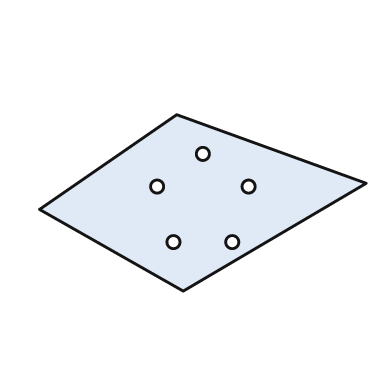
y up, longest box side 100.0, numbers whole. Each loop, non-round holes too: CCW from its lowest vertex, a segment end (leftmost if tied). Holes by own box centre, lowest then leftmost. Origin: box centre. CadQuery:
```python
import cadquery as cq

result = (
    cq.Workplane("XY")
    .moveTo(-6.0, -27.0)
    .lineTo(50.0, 6.0)
    .lineTo(-8.0, 27.0)
    .lineTo(-50.0, -2.0)
    .close()
    .moveTo(-9.0, -12.0)
    .circle(2.0)
    .moveTo(9.0, -12.0)
    .circle(2.0)
    .moveTo(-14.0, 5.0)
    .circle(2.0)
    .moveTo(14.0, 5.0)
    .circle(2.0)
    .moveTo(0.0, 15.0)
    .circle(2.0)
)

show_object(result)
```